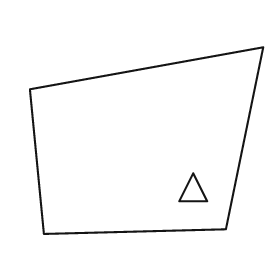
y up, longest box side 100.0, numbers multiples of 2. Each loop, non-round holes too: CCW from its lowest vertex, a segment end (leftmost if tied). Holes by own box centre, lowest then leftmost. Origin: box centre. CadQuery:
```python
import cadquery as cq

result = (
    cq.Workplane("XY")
    .moveTo(-44.0, -40.0)
    .lineTo(34.0, -38.0)
    .lineTo(50.0, 40.0)
    .lineTo(-50.0, 22.0)
    .close()
    .moveTo(14.0, -26.0)
    .lineTo(26.0, -26.0)
    .lineTo(20.0, -14.0)
    .close()
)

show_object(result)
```